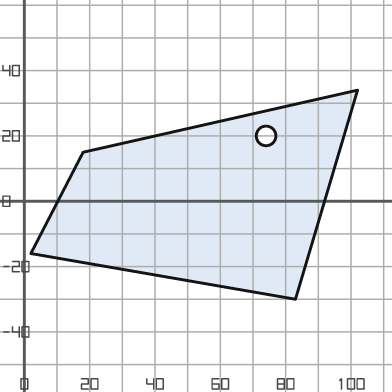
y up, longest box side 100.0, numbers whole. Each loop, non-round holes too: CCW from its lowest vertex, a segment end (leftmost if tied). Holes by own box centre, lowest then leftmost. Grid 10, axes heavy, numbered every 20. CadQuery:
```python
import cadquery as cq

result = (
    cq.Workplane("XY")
    .moveTo(83.0, -30.0)
    .lineTo(102.0, 34.0)
    .lineTo(18.0, 15.0)
    .lineTo(2.0, -16.0)
    .close()
    .moveTo(74.0, 20.0)
    .circle(3.0)
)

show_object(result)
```